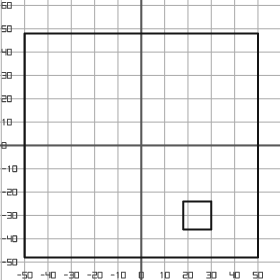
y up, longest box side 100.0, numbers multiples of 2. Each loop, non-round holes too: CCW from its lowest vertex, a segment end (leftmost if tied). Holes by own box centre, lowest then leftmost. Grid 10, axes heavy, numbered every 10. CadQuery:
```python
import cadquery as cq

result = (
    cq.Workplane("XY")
    .moveTo(-50.0, -48.0)
    .lineTo(50.0, -48.0)
    .lineTo(50.0, 48.0)
    .lineTo(-50.0, 48.0)
    .close()
    .moveTo(18.0, -36.0)
    .lineTo(30.0, -36.0)
    .lineTo(30.0, -24.0)
    .lineTo(18.0, -24.0)
    .close()
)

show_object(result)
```